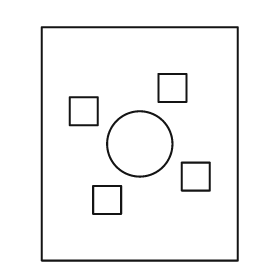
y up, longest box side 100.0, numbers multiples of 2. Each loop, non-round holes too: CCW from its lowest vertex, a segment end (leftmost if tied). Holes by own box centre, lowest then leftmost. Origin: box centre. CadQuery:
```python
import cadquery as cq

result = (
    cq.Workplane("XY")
    .moveTo(-42.0, -50.0)
    .lineTo(42.0, -50.0)
    .lineTo(42.0, 50.0)
    .lineTo(-42.0, 50.0)
    .close()
    .moveTo(-20.0, -30.0)
    .lineTo(-8.0, -30.0)
    .lineTo(-8.0, -18.0)
    .lineTo(-20.0, -18.0)
    .close()
    .moveTo(18.0, -20.0)
    .lineTo(30.0, -20.0)
    .lineTo(30.0, -8.0)
    .lineTo(18.0, -8.0)
    .close()
    .moveTo(0.0, 0.0)
    .circle(14.0)
    .moveTo(-30.0, 8.0)
    .lineTo(-18.0, 8.0)
    .lineTo(-18.0, 20.0)
    .lineTo(-30.0, 20.0)
    .close()
    .moveTo(8.0, 18.0)
    .lineTo(20.0, 18.0)
    .lineTo(20.0, 30.0)
    .lineTo(8.0, 30.0)
    .close()
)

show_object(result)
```